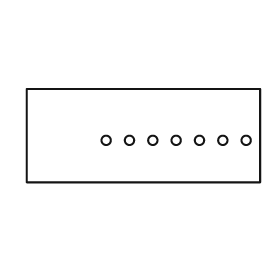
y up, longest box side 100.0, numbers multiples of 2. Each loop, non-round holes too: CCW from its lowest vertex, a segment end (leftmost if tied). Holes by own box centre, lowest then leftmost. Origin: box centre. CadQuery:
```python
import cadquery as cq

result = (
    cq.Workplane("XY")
    .moveTo(-50.0, -20.0)
    .lineTo(50.0, -20.0)
    .lineTo(50.0, 20.0)
    .lineTo(-50.0, 20.0)
    .close()
    .moveTo(-16.0, -2.0)
    .circle(2.0)
    .moveTo(-6.0, -2.0)
    .circle(2.0)
    .moveTo(4.0, -2.0)
    .circle(2.0)
    .moveTo(14.0, -2.0)
    .circle(2.0)
    .moveTo(24.0, -2.0)
    .circle(2.0)
    .moveTo(34.0, -2.0)
    .circle(2.0)
    .moveTo(44.0, -2.0)
    .circle(2.0)
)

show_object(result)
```